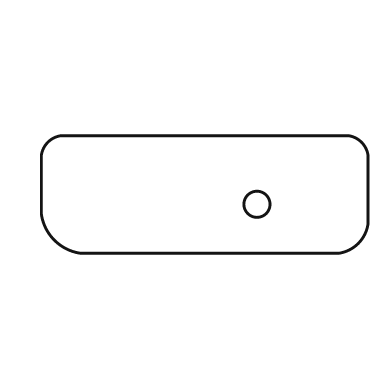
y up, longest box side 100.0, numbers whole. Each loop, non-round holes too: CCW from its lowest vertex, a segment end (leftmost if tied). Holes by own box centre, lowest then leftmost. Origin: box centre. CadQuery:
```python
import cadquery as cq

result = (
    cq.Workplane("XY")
    .moveTo(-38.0, -18.0)
    .lineTo(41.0, -18.0)
    .threePointArc((47.0, -15.0), (50.0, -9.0))
    .lineTo(50.0, 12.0)
    .threePointArc((48.0, 16.0), (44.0, 18.0))
    .lineTo(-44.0, 18.0)
    .threePointArc((-48.0, 16.0), (-50.0, 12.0))
    .lineTo(-50.0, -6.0)
    .threePointArc((-46.0, -14.0), (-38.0, -18.0))
    .close()
    .moveTo(16.0, -3.0)
    .circle(4.0)
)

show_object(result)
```